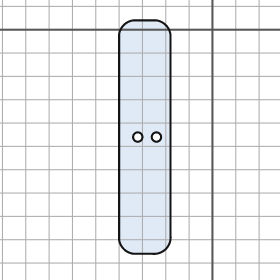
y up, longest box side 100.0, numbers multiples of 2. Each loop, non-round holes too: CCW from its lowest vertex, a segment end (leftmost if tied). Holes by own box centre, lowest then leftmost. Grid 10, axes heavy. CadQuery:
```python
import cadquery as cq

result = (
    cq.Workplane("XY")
    .moveTo(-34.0, -96.0)
    .lineTo(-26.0, -96.0)
    .threePointArc((-20.0, -94.0), (-18.0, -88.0))
    .lineTo(-18.0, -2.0)
    .threePointArc((-20.0, 2.0), (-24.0, 4.0))
    .lineTo(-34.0, 4.0)
    .threePointArc((-38.0, 2.0), (-40.0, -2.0))
    .lineTo(-40.0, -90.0)
    .threePointArc((-38.0, -94.0), (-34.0, -96.0))
    .close()
    .moveTo(-32.0, -46.0)
    .circle(2.0)
    .moveTo(-24.0, -46.0)
    .circle(2.0)
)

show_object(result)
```